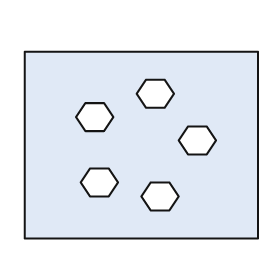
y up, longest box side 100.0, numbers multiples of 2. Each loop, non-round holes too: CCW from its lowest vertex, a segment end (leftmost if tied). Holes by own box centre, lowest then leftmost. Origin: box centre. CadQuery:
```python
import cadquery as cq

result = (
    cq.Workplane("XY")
    .moveTo(-50.0, -40.0)
    .lineTo(50.0, -40.0)
    .lineTo(50.0, 40.0)
    .lineTo(-50.0, 40.0)
    .close()
    .moveTo(4.0, -28.0)
    .lineTo(12.0, -28.0)
    .lineTo(16.0, -22.0)
    .lineTo(12.0, -16.0)
    .lineTo(4.0, -16.0)
    .lineTo(0.0, -22.0)
    .close()
    .moveTo(-22.0, -22.0)
    .lineTo(-14.0, -22.0)
    .lineTo(-10.0, -16.0)
    .lineTo(-14.0, -10.0)
    .lineTo(-22.0, -10.0)
    .lineTo(-26.0, -16.0)
    .close()
    .moveTo(20.0, -4.0)
    .lineTo(28.0, -4.0)
    .lineTo(32.0, 2.0)
    .lineTo(28.0, 8.0)
    .lineTo(20.0, 8.0)
    .lineTo(16.0, 2.0)
    .close()
    .moveTo(-24.0, 6.0)
    .lineTo(-16.0, 6.0)
    .lineTo(-12.0, 12.0)
    .lineTo(-16.0, 18.0)
    .lineTo(-24.0, 18.0)
    .lineTo(-28.0, 12.0)
    .close()
    .moveTo(2.0, 16.0)
    .lineTo(10.0, 16.0)
    .lineTo(14.0, 22.0)
    .lineTo(10.0, 28.0)
    .lineTo(2.0, 28.0)
    .lineTo(-2.0, 22.0)
    .close()
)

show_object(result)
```